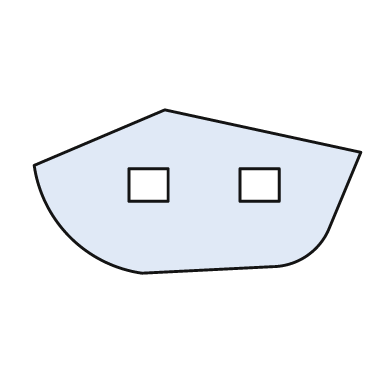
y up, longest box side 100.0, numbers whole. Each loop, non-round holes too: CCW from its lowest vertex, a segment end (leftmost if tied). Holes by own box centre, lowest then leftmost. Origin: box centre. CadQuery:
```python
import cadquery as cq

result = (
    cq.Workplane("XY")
    .moveTo(-17.0, -25.0)
    .lineTo(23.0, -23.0)
    .threePointArc((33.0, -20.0), (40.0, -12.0))
    .lineTo(50.0, 12.0)
    .lineTo(-10.0, 25.0)
    .lineTo(-50.0, 8.0)
    .threePointArc((-39.0, -14.0), (-17.0, -25.0))
    .close()
    .moveTo(-21.0, -3.0)
    .lineTo(-9.0, -3.0)
    .lineTo(-9.0, 7.0)
    .lineTo(-21.0, 7.0)
    .close()
    .moveTo(13.0, -3.0)
    .lineTo(25.0, -3.0)
    .lineTo(25.0, 7.0)
    .lineTo(13.0, 7.0)
    .close()
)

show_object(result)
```